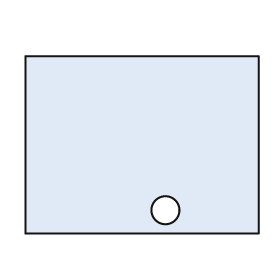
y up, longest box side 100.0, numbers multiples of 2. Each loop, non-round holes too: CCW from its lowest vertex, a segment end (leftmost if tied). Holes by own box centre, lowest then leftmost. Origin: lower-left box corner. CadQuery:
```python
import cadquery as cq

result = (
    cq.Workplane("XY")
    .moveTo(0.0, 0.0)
    .lineTo(100.0, 0.0)
    .lineTo(100.0, 76.0)
    .lineTo(0.0, 76.0)
    .close()
    .moveTo(60.0, 10.0)
    .circle(6.0)
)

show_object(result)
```